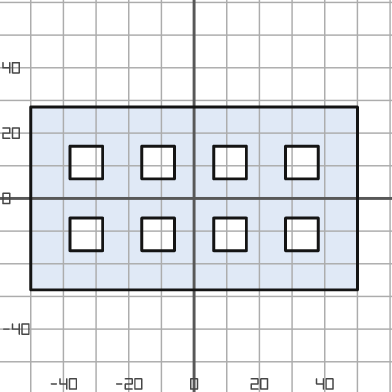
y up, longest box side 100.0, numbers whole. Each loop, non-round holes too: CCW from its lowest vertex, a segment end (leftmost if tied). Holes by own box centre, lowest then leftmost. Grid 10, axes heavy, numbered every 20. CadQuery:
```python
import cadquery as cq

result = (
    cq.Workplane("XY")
    .moveTo(-50.0, -28.0)
    .lineTo(50.0, -28.0)
    .lineTo(50.0, 28.0)
    .lineTo(-50.0, 28.0)
    .close()
    .moveTo(-38.0, -16.0)
    .lineTo(-28.0, -16.0)
    .lineTo(-28.0, -6.0)
    .lineTo(-38.0, -6.0)
    .close()
    .moveTo(-16.0, -16.0)
    .lineTo(-6.0, -16.0)
    .lineTo(-6.0, -6.0)
    .lineTo(-16.0, -6.0)
    .close()
    .moveTo(6.0, -16.0)
    .lineTo(16.0, -16.0)
    .lineTo(16.0, -6.0)
    .lineTo(6.0, -6.0)
    .close()
    .moveTo(28.0, -16.0)
    .lineTo(38.0, -16.0)
    .lineTo(38.0, -6.0)
    .lineTo(28.0, -6.0)
    .close()
    .moveTo(-38.0, 6.0)
    .lineTo(-28.0, 6.0)
    .lineTo(-28.0, 16.0)
    .lineTo(-38.0, 16.0)
    .close()
    .moveTo(-16.0, 6.0)
    .lineTo(-6.0, 6.0)
    .lineTo(-6.0, 16.0)
    .lineTo(-16.0, 16.0)
    .close()
    .moveTo(6.0, 6.0)
    .lineTo(16.0, 6.0)
    .lineTo(16.0, 16.0)
    .lineTo(6.0, 16.0)
    .close()
    .moveTo(28.0, 6.0)
    .lineTo(38.0, 6.0)
    .lineTo(38.0, 16.0)
    .lineTo(28.0, 16.0)
    .close()
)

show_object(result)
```